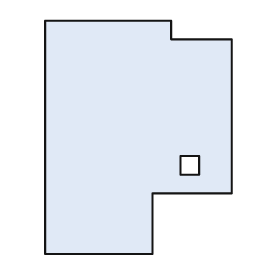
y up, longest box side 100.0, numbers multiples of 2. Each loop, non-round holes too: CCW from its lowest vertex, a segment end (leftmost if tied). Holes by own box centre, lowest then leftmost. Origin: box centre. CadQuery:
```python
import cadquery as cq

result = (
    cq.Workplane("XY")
    .moveTo(-40.0, -50.0)
    .lineTo(6.0, -50.0)
    .lineTo(6.0, -24.0)
    .lineTo(40.0, -24.0)
    .lineTo(40.0, 42.0)
    .lineTo(14.0, 42.0)
    .lineTo(14.0, 50.0)
    .lineTo(-40.0, 50.0)
    .close()
    .moveTo(18.0, -16.0)
    .lineTo(26.0, -16.0)
    .lineTo(26.0, -8.0)
    .lineTo(18.0, -8.0)
    .close()
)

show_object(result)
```